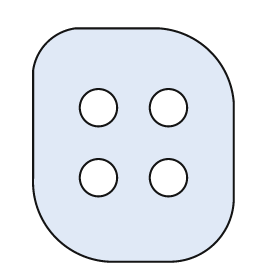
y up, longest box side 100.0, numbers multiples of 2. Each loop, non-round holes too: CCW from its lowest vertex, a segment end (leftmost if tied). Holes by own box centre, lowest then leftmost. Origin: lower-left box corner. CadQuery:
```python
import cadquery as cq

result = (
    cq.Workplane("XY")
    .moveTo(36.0, 0.0)
    .lineTo(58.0, 0.0)
    .threePointArc((78.0, 8.0), (86.0, 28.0))
    .lineTo(86.0, 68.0)
    .threePointArc((76.0, 90.0), (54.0, 100.0))
    .lineTo(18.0, 100.0)
    .threePointArc((6.0, 94.0), (0.0, 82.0))
    .lineTo(0.0, 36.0)
    .threePointArc((10.0, 10.0), (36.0, 0.0))
    .close()
    .moveTo(28.0, 36.0)
    .circle(8.0)
    .moveTo(58.0, 36.0)
    .circle(8.0)
    .moveTo(28.0, 66.0)
    .circle(8.0)
    .moveTo(58.0, 66.0)
    .circle(8.0)
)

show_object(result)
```